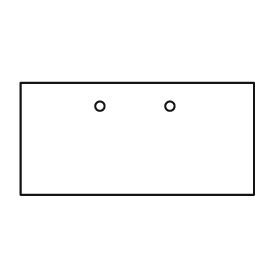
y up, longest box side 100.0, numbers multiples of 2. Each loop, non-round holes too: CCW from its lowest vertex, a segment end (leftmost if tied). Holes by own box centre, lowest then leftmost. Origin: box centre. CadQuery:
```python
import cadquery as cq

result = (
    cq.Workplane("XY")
    .moveTo(-50.0, -24.0)
    .lineTo(50.0, -24.0)
    .lineTo(50.0, 24.0)
    .lineTo(-50.0, 24.0)
    .close()
    .moveTo(-16.0, 14.0)
    .circle(2.0)
    .moveTo(14.0, 14.0)
    .circle(2.0)
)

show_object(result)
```